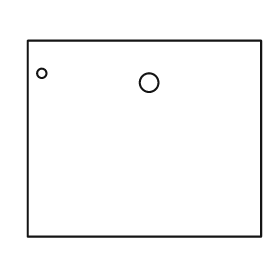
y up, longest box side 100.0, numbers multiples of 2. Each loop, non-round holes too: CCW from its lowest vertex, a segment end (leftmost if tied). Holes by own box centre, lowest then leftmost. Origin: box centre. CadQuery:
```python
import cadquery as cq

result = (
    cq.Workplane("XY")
    .moveTo(-50.0, -42.0)
    .lineTo(50.0, -42.0)
    .lineTo(50.0, 42.0)
    .lineTo(-50.0, 42.0)
    .close()
    .moveTo(2.0, 24.0)
    .circle(4.0)
    .moveTo(-44.0, 28.0)
    .circle(2.0)
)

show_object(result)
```